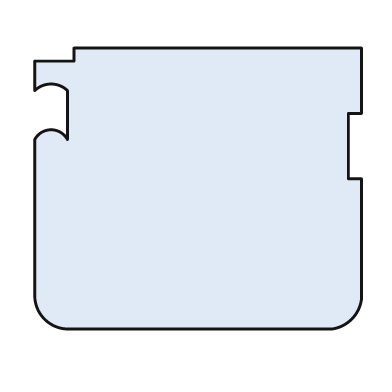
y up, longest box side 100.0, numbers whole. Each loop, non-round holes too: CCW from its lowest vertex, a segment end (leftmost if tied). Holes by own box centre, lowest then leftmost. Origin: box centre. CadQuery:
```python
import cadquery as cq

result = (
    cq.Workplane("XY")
    .moveTo(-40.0, -43.0)
    .lineTo(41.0, -43.0)
    .threePointArc((47.0, -40.0), (50.0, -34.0))
    .lineTo(50.0, 3.0)
    .lineTo(46.0, 3.0)
    .lineTo(46.0, 23.0)
    .lineTo(50.0, 23.0)
    .lineTo(50.0, 43.0)
    .lineTo(-38.0, 43.0)
    .lineTo(-38.0, 39.0)
    .lineTo(-50.0, 39.0)
    .lineTo(-50.0, 30.0)
    .threePointArc((-45.0, 32.0), (-40.0, 30.0))
    .lineTo(-40.0, 15.0)
    .threePointArc((-45.0, 18.0), (-50.0, 15.0))
    .lineTo(-50.0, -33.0)
    .threePointArc((-47.0, -40.0), (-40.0, -43.0))
    .close()
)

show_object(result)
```